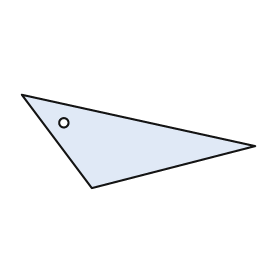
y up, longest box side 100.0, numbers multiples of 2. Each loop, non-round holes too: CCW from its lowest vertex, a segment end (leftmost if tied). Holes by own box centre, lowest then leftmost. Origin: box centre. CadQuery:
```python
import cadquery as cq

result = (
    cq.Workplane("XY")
    .moveTo(-20.0, -20.0)
    .lineTo(50.0, -2.0)
    .lineTo(-50.0, 20.0)
    .close()
    .moveTo(-32.0, 8.0)
    .circle(2.0)
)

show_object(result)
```